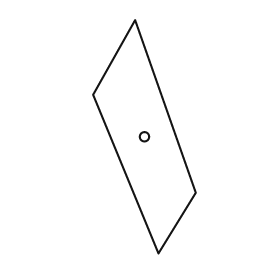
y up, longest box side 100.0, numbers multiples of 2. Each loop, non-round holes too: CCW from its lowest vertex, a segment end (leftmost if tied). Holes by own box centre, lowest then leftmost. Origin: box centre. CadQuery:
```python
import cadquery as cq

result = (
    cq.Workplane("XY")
    .moveTo(6.0, -50.0)
    .lineTo(22.0, -24.0)
    .lineTo(-4.0, 50.0)
    .lineTo(-22.0, 18.0)
    .close()
    .moveTo(0.0, 0.0)
    .circle(2.0)
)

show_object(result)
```